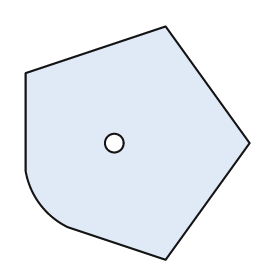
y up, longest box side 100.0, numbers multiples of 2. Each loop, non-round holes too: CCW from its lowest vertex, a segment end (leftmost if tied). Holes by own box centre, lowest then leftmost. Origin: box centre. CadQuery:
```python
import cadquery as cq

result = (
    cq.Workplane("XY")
    .moveTo(12.0, -50.0)
    .lineTo(48.0, 0.0)
    .lineTo(12.0, 50.0)
    .lineTo(-48.0, 30.0)
    .lineTo(-48.0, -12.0)
    .threePointArc((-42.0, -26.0), (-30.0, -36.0))
    .close()
    .moveTo(-10.0, 0.0)
    .circle(4.0)
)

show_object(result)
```